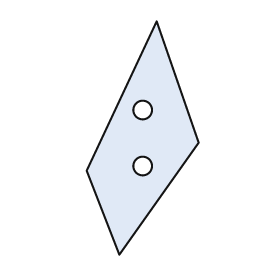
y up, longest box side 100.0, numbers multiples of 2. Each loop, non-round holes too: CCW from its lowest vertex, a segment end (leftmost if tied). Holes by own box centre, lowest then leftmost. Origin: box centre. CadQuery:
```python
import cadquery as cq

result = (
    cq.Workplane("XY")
    .moveTo(-10.0, -50.0)
    .lineTo(24.0, -2.0)
    .lineTo(6.0, 50.0)
    .lineTo(-24.0, -14.0)
    .close()
    .moveTo(0.0, -12.0)
    .circle(4.0)
    .moveTo(0.0, 12.0)
    .circle(4.0)
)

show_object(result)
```